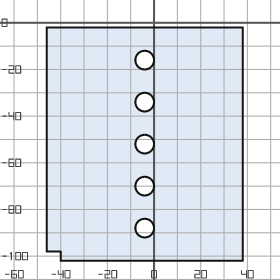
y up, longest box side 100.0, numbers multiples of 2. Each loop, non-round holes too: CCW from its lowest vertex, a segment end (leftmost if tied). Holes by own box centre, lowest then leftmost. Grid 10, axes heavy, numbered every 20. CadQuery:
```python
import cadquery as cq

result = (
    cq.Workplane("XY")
    .moveTo(-40.0, -102.0)
    .lineTo(38.0, -102.0)
    .lineTo(38.0, -2.0)
    .lineTo(-46.0, -2.0)
    .lineTo(-46.0, -98.0)
    .lineTo(-40.0, -98.0)
    .close()
    .moveTo(-4.0, -88.0)
    .circle(4.0)
    .moveTo(-4.0, -70.0)
    .circle(4.0)
    .moveTo(-4.0, -52.0)
    .circle(4.0)
    .moveTo(-4.0, -34.0)
    .circle(4.0)
    .moveTo(-4.0, -16.0)
    .circle(4.0)
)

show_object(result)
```